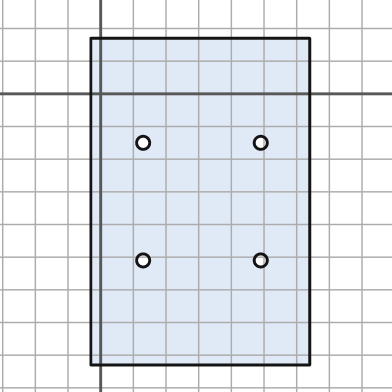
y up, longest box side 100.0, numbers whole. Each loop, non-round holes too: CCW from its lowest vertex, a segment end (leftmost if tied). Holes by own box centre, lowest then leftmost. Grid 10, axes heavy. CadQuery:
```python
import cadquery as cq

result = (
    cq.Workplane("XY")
    .moveTo(-3.0, -83.0)
    .lineTo(64.0, -83.0)
    .lineTo(64.0, 17.0)
    .lineTo(-3.0, 17.0)
    .close()
    .moveTo(13.0, -51.0)
    .circle(2.0)
    .moveTo(49.0, -51.0)
    .circle(2.0)
    .moveTo(13.0, -15.0)
    .circle(2.0)
    .moveTo(49.0, -15.0)
    .circle(2.0)
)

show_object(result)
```